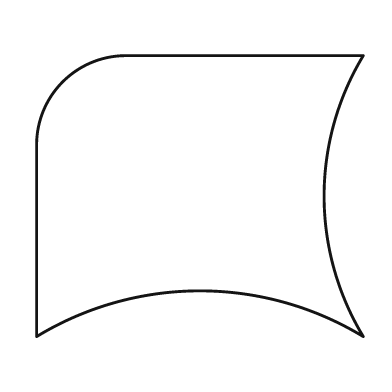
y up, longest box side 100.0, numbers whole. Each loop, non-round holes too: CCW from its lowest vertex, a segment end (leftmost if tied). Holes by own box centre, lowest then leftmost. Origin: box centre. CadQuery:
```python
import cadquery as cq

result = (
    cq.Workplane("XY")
    .moveTo(-50.0, -43.0)
    .threePointArc((0.0, -29.0), (50.0, -43.0))
    .threePointArc((38.0, 0.0), (50.0, 43.0))
    .lineTo(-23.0, 43.0)
    .threePointArc((-42.0, 35.0), (-50.0, 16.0))
    .close()
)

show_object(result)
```